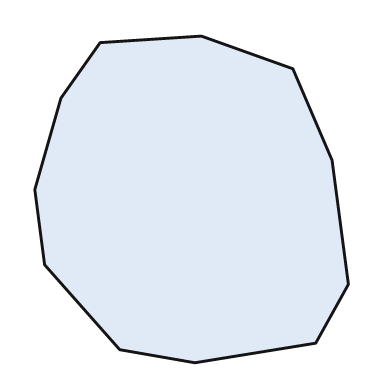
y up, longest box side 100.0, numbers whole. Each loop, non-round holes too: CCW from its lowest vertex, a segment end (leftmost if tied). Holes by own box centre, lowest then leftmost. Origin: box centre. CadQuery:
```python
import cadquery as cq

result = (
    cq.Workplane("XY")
    .moveTo(1.0, -50.0)
    .lineTo(38.0, -44.0)
    .lineTo(48.0, -26.0)
    .lineTo(43.0, 12.0)
    .lineTo(31.0, 40.0)
    .lineTo(3.0, 50.0)
    .lineTo(-28.0, 48.0)
    .lineTo(-40.0, 31.0)
    .lineTo(-48.0, 3.0)
    .lineTo(-45.0, -20.0)
    .lineTo(-22.0, -46.0)
    .close()
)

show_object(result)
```